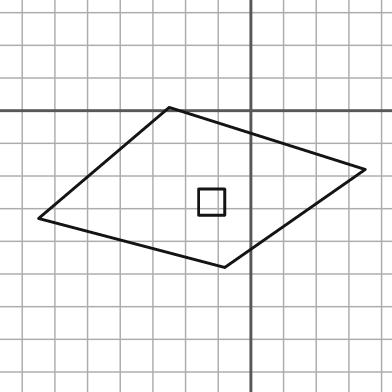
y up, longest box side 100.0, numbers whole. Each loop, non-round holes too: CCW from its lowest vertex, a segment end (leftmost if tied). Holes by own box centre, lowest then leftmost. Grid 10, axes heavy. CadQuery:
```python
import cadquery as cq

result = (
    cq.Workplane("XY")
    .moveTo(-8.0, -48.0)
    .lineTo(35.0, -18.0)
    .lineTo(-25.0, 1.0)
    .lineTo(-65.0, -33.0)
    .close()
    .moveTo(-16.0, -32.0)
    .lineTo(-8.0, -32.0)
    .lineTo(-8.0, -24.0)
    .lineTo(-16.0, -24.0)
    .close()
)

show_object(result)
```